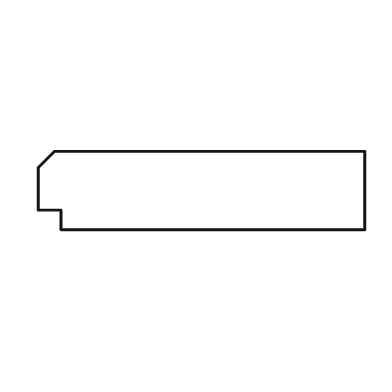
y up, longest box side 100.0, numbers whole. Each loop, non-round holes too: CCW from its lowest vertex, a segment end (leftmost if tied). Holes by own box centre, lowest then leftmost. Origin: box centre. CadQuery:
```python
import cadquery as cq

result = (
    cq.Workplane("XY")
    .moveTo(-43.0, -12.0)
    .lineTo(50.0, -12.0)
    .lineTo(50.0, 12.0)
    .lineTo(-45.0, 12.0)
    .lineTo(-50.0, 7.0)
    .lineTo(-50.0, -6.0)
    .lineTo(-43.0, -6.0)
    .close()
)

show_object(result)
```